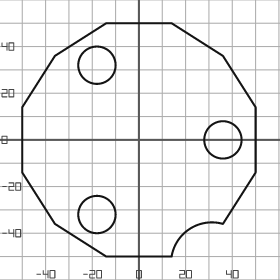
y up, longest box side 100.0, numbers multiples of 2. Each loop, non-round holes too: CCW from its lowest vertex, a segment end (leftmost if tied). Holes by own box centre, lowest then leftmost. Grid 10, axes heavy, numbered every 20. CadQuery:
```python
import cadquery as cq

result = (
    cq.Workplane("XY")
    .moveTo(-14.0, -50.0)
    .lineTo(14.0, -50.0)
    .threePointArc((22.0, -38.0), (36.0, -36.0))
    .lineTo(50.0, -14.0)
    .lineTo(50.0, 14.0)
    .lineTo(36.0, 36.0)
    .lineTo(14.0, 50.0)
    .lineTo(-14.0, 50.0)
    .lineTo(-36.0, 36.0)
    .lineTo(-50.0, 14.0)
    .lineTo(-50.0, -14.0)
    .lineTo(-36.0, -36.0)
    .close()
    .moveTo(-18.0, -32.0)
    .circle(8.0)
    .moveTo(36.0, 0.0)
    .circle(8.0)
    .moveTo(-18.0, 32.0)
    .circle(8.0)
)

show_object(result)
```